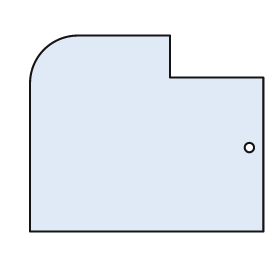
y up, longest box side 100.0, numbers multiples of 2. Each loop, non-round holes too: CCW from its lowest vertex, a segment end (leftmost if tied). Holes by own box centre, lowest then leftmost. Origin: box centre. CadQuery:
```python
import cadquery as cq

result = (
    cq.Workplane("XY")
    .moveTo(-50.0, -42.0)
    .lineTo(50.0, -42.0)
    .lineTo(50.0, 24.0)
    .lineTo(10.0, 24.0)
    .lineTo(10.0, 42.0)
    .lineTo(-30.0, 42.0)
    .threePointArc((-44.0, 36.0), (-50.0, 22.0))
    .close()
    .moveTo(44.0, -6.0)
    .circle(2.0)
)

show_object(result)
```